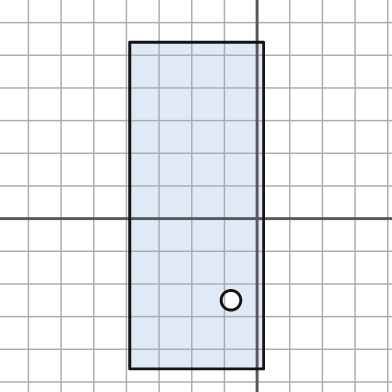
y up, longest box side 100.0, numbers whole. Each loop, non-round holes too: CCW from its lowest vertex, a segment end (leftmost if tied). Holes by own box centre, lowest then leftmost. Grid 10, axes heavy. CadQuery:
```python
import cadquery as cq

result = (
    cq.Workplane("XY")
    .moveTo(-39.0, -46.0)
    .lineTo(2.0, -46.0)
    .lineTo(2.0, 54.0)
    .lineTo(-39.0, 54.0)
    .close()
    .moveTo(-8.0, -25.0)
    .circle(3.0)
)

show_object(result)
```